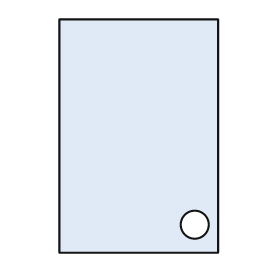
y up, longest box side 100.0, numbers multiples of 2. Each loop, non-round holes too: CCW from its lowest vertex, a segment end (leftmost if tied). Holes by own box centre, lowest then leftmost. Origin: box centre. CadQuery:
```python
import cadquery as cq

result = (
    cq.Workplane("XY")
    .moveTo(-34.0, -50.0)
    .lineTo(34.0, -50.0)
    .lineTo(34.0, 50.0)
    .lineTo(-34.0, 50.0)
    .close()
    .moveTo(24.0, -38.0)
    .circle(6.0)
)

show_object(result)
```